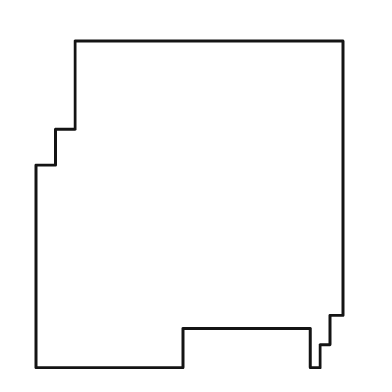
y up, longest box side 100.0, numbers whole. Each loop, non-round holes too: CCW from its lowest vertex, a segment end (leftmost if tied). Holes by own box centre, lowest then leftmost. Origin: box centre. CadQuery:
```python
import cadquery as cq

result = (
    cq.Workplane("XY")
    .moveTo(-47.0, -50.0)
    .lineTo(-2.0, -50.0)
    .lineTo(-2.0, -38.0)
    .lineTo(37.0, -38.0)
    .lineTo(37.0, -50.0)
    .lineTo(40.0, -50.0)
    .lineTo(40.0, -43.0)
    .lineTo(43.0, -43.0)
    .lineTo(43.0, -34.0)
    .lineTo(47.0, -34.0)
    .lineTo(47.0, 50.0)
    .lineTo(-35.0, 50.0)
    .lineTo(-35.0, 23.0)
    .lineTo(-41.0, 23.0)
    .lineTo(-41.0, 12.0)
    .lineTo(-47.0, 12.0)
    .close()
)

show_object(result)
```